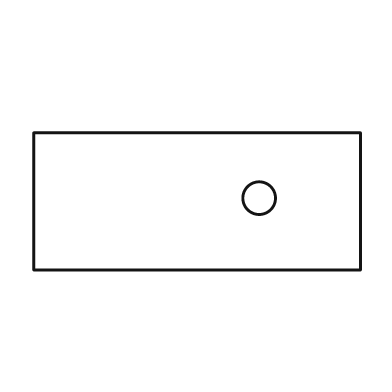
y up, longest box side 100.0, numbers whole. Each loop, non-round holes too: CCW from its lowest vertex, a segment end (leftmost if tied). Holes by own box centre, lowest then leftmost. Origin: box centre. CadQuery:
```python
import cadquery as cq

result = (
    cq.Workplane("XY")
    .moveTo(-50.0, -21.0)
    .lineTo(50.0, -21.0)
    .lineTo(50.0, 21.0)
    .lineTo(-50.0, 21.0)
    .close()
    .moveTo(19.0, 1.0)
    .circle(5.0)
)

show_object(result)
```